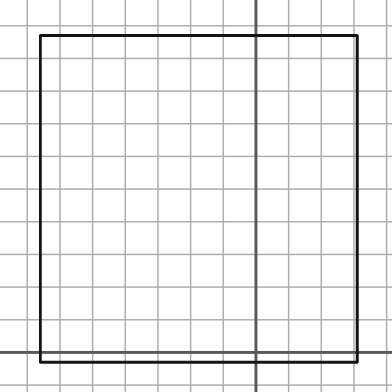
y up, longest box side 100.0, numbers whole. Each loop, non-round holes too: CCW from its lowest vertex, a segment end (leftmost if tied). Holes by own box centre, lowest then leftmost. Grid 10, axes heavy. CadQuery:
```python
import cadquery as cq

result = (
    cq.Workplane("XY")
    .moveTo(-66.0, -3.0)
    .lineTo(31.0, -3.0)
    .lineTo(31.0, 97.0)
    .lineTo(-66.0, 97.0)
    .close()
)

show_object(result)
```